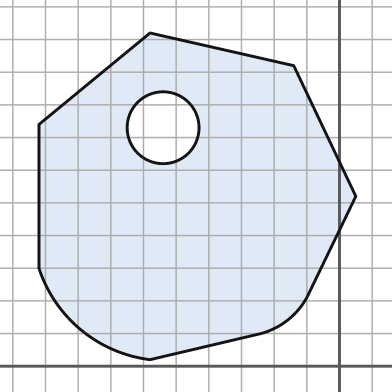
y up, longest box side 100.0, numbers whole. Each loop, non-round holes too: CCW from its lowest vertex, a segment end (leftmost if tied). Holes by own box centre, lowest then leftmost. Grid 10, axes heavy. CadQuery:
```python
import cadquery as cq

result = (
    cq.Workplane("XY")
    .moveTo(-58.0, 2.0)
    .lineTo(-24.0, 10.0)
    .threePointArc((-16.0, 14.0), (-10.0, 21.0))
    .lineTo(5.0, 52.0)
    .lineTo(-14.0, 92.0)
    .lineTo(-58.0, 102.0)
    .lineTo(-92.0, 74.0)
    .lineTo(-92.0, 30.0)
    .threePointArc((-79.0, 11.0), (-58.0, 2.0))
    .close()
    .moveTo(-54.0, 73.0)
    .circle(11.0)
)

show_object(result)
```